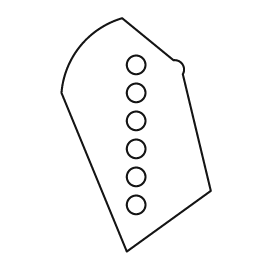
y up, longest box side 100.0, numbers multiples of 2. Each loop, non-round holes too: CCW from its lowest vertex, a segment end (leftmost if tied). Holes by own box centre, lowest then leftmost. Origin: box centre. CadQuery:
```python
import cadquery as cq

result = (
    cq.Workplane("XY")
    .moveTo(-4.0, -50.0)
    .lineTo(32.0, -24.0)
    .lineTo(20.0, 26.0)
    .threePointArc((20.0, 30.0), (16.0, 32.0))
    .lineTo(-6.0, 50.0)
    .threePointArc((-24.0, 38.0), (-32.0, 18.0))
    .close()
    .moveTo(0.0, -30.0)
    .circle(4.0)
    .moveTo(0.0, -18.0)
    .circle(4.0)
    .moveTo(0.0, -6.0)
    .circle(4.0)
    .moveTo(0.0, 6.0)
    .circle(4.0)
    .moveTo(0.0, 18.0)
    .circle(4.0)
    .moveTo(0.0, 30.0)
    .circle(4.0)
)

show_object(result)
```